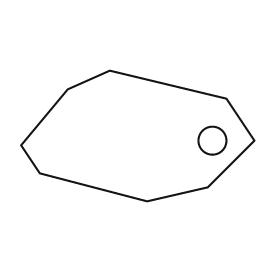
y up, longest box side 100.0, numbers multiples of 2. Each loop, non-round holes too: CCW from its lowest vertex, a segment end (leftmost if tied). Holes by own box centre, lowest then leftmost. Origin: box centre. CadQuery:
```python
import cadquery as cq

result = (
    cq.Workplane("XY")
    .moveTo(4.0, -28.0)
    .lineTo(30.0, -22.0)
    .lineTo(50.0, -2.0)
    .lineTo(38.0, 16.0)
    .lineTo(-12.0, 28.0)
    .lineTo(-30.0, 20.0)
    .lineTo(-50.0, -4.0)
    .lineTo(-42.0, -16.0)
    .close()
    .moveTo(32.0, -2.0)
    .circle(6.0)
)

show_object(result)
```